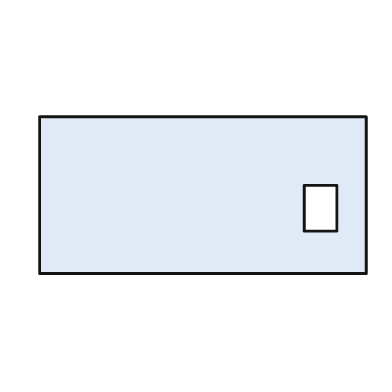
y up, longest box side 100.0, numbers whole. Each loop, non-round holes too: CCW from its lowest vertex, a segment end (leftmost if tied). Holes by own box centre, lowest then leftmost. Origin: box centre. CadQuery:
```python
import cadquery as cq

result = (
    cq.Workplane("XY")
    .moveTo(-50.0, -24.0)
    .lineTo(50.0, -24.0)
    .lineTo(50.0, 24.0)
    .lineTo(-50.0, 24.0)
    .close()
    .moveTo(31.0, -11.0)
    .lineTo(41.0, -11.0)
    .lineTo(41.0, 3.0)
    .lineTo(31.0, 3.0)
    .close()
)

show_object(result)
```